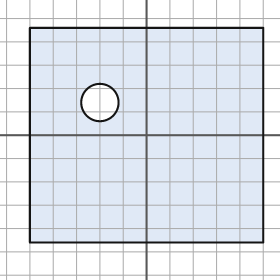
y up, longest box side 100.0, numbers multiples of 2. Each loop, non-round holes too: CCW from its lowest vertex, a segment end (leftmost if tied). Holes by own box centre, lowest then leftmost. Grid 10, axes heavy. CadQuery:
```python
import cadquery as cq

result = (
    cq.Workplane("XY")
    .moveTo(-50.0, -46.0)
    .lineTo(50.0, -46.0)
    .lineTo(50.0, 46.0)
    .lineTo(-50.0, 46.0)
    .close()
    .moveTo(-20.0, 14.0)
    .circle(8.0)
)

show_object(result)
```